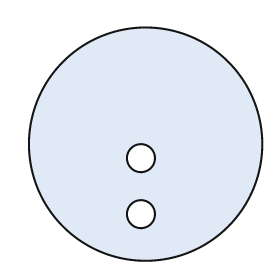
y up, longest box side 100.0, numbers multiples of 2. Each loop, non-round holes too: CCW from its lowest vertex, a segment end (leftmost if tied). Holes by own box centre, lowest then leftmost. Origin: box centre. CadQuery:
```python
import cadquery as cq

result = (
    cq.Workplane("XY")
    .moveTo(0.0, 0.0)
    .circle(50.0)
    .moveTo(-2.0, -30.0)
    .circle(6.0)
    .moveTo(-2.0, -6.0)
    .circle(6.0)
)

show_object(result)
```